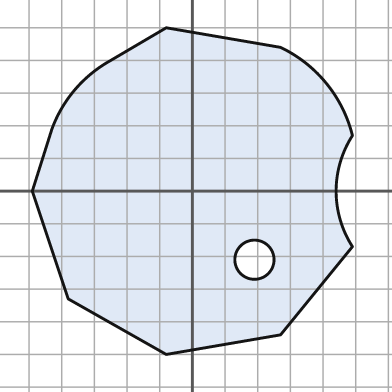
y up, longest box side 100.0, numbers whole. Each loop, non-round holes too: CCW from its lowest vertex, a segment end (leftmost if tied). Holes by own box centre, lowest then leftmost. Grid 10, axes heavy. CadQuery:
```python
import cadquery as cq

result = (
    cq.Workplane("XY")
    .moveTo(-8.0, -50.0)
    .lineTo(27.0, -44.0)
    .lineTo(49.0, -17.0)
    .threePointArc((44.0, 0.0), (49.0, 17.0))
    .threePointArc((41.0, 33.0), (27.0, 44.0))
    .lineTo(-8.0, 50.0)
    .lineTo(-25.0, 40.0)
    .threePointArc((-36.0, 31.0), (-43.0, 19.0))
    .lineTo(-49.0, 0.0)
    .lineTo(-38.0, -33.0)
    .close()
    .moveTo(19.0, -21.0)
    .circle(6.0)
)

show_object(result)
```